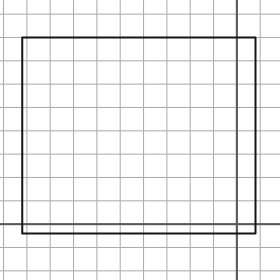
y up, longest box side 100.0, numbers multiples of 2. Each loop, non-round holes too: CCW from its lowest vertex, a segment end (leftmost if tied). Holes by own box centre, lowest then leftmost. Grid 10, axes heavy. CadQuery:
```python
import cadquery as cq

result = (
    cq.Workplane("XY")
    .moveTo(-92.0, -4.0)
    .lineTo(8.0, -4.0)
    .lineTo(8.0, 80.0)
    .lineTo(-92.0, 80.0)
    .close()
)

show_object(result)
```